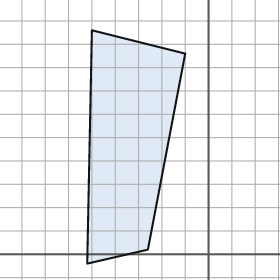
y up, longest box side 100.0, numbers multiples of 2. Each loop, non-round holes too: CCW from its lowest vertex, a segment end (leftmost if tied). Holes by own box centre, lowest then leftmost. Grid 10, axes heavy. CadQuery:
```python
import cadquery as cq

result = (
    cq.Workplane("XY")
    .moveTo(-52.0, -4.0)
    .lineTo(-26.0, 2.0)
    .lineTo(-10.0, 86.0)
    .lineTo(-50.0, 96.0)
    .close()
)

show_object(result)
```